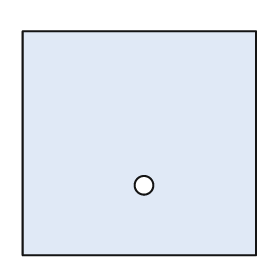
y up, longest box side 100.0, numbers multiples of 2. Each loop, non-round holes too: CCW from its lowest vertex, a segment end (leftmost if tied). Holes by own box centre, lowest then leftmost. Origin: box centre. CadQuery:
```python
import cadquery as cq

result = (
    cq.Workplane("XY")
    .moveTo(-50.0, -48.0)
    .lineTo(50.0, -48.0)
    .lineTo(50.0, 48.0)
    .lineTo(-50.0, 48.0)
    .close()
    .moveTo(2.0, -18.0)
    .circle(4.0)
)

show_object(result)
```